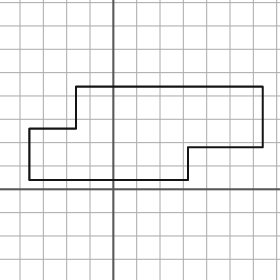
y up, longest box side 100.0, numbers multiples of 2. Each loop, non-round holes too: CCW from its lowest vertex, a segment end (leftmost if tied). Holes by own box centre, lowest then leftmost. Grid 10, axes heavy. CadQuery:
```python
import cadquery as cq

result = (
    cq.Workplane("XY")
    .moveTo(-36.0, 4.0)
    .lineTo(32.0, 4.0)
    .lineTo(32.0, 18.0)
    .lineTo(64.0, 18.0)
    .lineTo(64.0, 44.0)
    .lineTo(-16.0, 44.0)
    .lineTo(-16.0, 26.0)
    .lineTo(-36.0, 26.0)
    .close()
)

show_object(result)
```